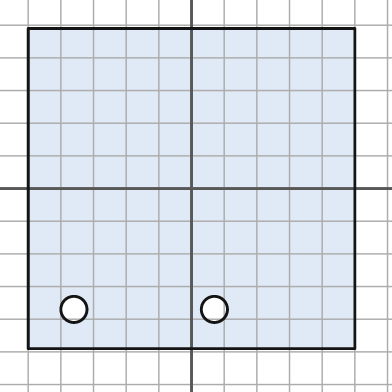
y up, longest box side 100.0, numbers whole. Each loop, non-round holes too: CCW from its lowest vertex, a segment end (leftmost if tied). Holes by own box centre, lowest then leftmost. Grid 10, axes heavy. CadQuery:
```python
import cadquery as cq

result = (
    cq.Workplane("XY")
    .moveTo(-50.0, -49.0)
    .lineTo(50.0, -49.0)
    .lineTo(50.0, 49.0)
    .lineTo(-50.0, 49.0)
    .close()
    .moveTo(-36.0, -37.0)
    .circle(4.0)
    .moveTo(7.0, -37.0)
    .circle(4.0)
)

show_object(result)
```